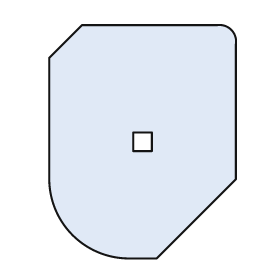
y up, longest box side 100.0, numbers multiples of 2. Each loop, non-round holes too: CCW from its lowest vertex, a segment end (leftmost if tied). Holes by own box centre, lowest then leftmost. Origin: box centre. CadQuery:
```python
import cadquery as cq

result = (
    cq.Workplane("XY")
    .moveTo(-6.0, -50.0)
    .lineTo(6.0, -50.0)
    .lineTo(40.0, -16.0)
    .lineTo(40.0, 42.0)
    .threePointArc((38.0, 48.0), (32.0, 50.0))
    .lineTo(-26.0, 50.0)
    .lineTo(-40.0, 36.0)
    .lineTo(-40.0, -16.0)
    .threePointArc((-30.0, -40.0), (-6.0, -50.0))
    .close()
    .moveTo(-4.0, -4.0)
    .lineTo(4.0, -4.0)
    .lineTo(4.0, 4.0)
    .lineTo(-4.0, 4.0)
    .close()
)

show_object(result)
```